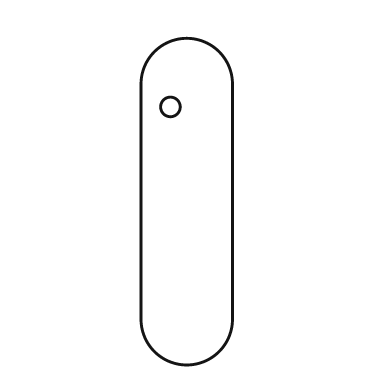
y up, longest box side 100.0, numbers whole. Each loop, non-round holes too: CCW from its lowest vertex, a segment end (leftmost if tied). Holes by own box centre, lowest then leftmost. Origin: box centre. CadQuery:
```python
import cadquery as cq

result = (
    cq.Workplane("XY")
    .moveTo(-14.0, -36.0)
    .threePointArc((0.0, -50.0), (14.0, -36.0))
    .lineTo(14.0, 36.0)
    .threePointArc((0.0, 50.0), (-14.0, 36.0))
    .close()
    .moveTo(-5.0, 29.0)
    .circle(3.0)
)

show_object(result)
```